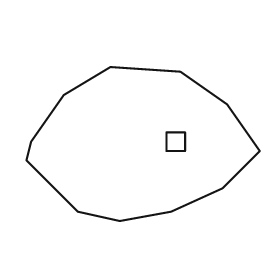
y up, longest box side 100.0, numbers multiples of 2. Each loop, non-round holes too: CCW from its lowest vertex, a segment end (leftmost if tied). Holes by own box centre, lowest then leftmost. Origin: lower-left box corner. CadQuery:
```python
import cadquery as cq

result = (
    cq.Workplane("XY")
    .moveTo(40.0, 0.0)
    .lineTo(62.0, 4.0)
    .lineTo(84.0, 14.0)
    .lineTo(100.0, 30.0)
    .lineTo(86.0, 50.0)
    .lineTo(66.0, 64.0)
    .lineTo(36.0, 66.0)
    .lineTo(16.0, 54.0)
    .lineTo(2.0, 34.0)
    .lineTo(0.0, 26.0)
    .lineTo(22.0, 4.0)
    .close()
    .moveTo(60.0, 30.0)
    .lineTo(68.0, 30.0)
    .lineTo(68.0, 38.0)
    .lineTo(60.0, 38.0)
    .close()
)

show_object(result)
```